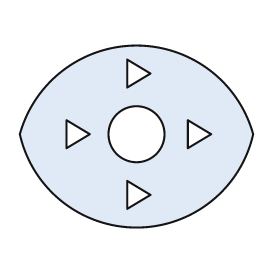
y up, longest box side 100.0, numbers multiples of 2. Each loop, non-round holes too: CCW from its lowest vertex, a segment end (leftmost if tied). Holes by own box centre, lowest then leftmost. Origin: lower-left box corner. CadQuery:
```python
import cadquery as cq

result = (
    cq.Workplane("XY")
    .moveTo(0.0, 40.0)
    .threePointArc((50.0, 0.0), (100.0, 40.0))
    .threePointArc((50.0, 78.0), (0.0, 40.0))
    .close()
    .moveTo(46.0, 8.0)
    .lineTo(56.0, 14.0)
    .lineTo(46.0, 20.0)
    .close()
    .moveTo(20.0, 34.0)
    .lineTo(30.0, 40.0)
    .lineTo(20.0, 46.0)
    .close()
    .moveTo(50.0, 40.0)
    .circle(12.0)
    .moveTo(72.0, 34.0)
    .lineTo(82.0, 40.0)
    .lineTo(72.0, 46.0)
    .close()
    .moveTo(46.0, 60.0)
    .lineTo(56.0, 66.0)
    .lineTo(46.0, 72.0)
    .close()
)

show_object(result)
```